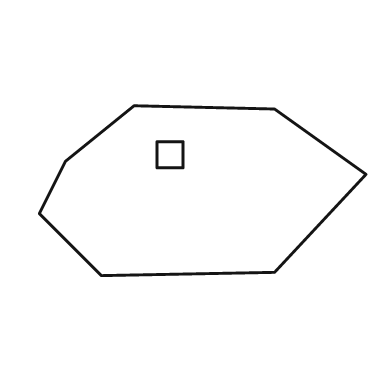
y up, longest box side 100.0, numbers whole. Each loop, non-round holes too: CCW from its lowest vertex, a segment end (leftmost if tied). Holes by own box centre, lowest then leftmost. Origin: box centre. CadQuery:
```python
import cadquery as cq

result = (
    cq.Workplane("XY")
    .moveTo(-31.0, -26.0)
    .lineTo(22.0, -25.0)
    .lineTo(50.0, 5.0)
    .lineTo(22.0, 25.0)
    .lineTo(-21.0, 26.0)
    .lineTo(-42.0, 9.0)
    .lineTo(-50.0, -7.0)
    .close()
    .moveTo(-14.0, 7.0)
    .lineTo(-6.0, 7.0)
    .lineTo(-6.0, 15.0)
    .lineTo(-14.0, 15.0)
    .close()
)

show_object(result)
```